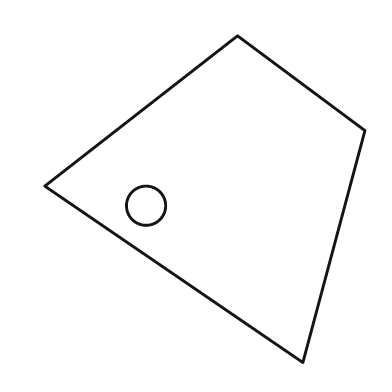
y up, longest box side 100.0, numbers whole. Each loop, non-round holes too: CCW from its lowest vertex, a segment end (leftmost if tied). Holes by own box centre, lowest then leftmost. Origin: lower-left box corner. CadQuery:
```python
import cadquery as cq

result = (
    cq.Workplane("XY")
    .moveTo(79.0, 0.0)
    .lineTo(98.0, 71.0)
    .lineTo(59.0, 100.0)
    .lineTo(0.0, 54.0)
    .close()
    .moveTo(31.0, 48.0)
    .circle(6.0)
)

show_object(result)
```